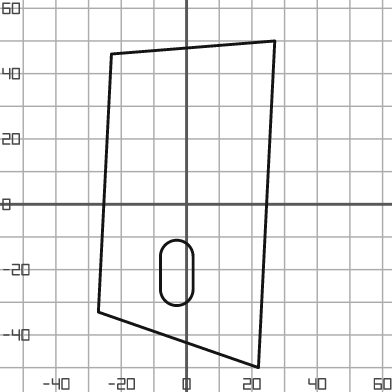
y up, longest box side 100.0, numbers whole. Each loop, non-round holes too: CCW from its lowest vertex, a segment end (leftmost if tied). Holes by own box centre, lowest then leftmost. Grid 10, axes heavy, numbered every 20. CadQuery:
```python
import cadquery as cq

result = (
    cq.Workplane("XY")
    .moveTo(22.0, -50.0)
    .lineTo(27.0, 50.0)
    .lineTo(-23.0, 46.0)
    .lineTo(-27.0, -33.0)
    .close()
    .moveTo(-8.0, -26.0)
    .threePointArc((-3.0, -31.0), (2.0, -26.0))
    .lineTo(2.0, -16.0)
    .threePointArc((-3.0, -11.0), (-8.0, -16.0))
    .close()
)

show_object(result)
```